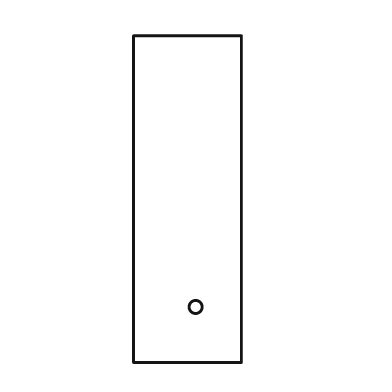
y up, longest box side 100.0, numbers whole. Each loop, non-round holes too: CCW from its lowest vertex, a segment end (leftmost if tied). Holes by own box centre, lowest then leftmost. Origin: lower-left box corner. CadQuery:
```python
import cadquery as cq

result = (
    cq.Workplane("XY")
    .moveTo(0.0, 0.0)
    .lineTo(33.0, 0.0)
    .lineTo(33.0, 100.0)
    .lineTo(0.0, 100.0)
    .close()
    .moveTo(19.0, 17.0)
    .circle(2.0)
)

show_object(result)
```